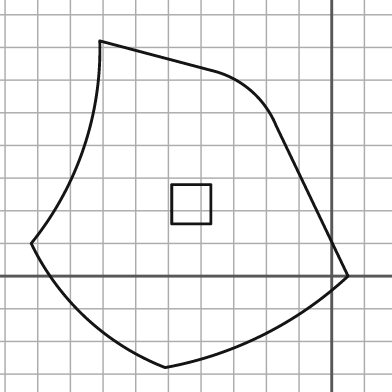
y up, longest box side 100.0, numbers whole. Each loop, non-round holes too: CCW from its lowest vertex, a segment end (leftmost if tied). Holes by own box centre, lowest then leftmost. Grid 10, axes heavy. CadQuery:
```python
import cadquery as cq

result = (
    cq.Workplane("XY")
    .moveTo(-51.0, -28.0)
    .threePointArc((-21.0, -18.0), (5.0, 0.0))
    .lineTo(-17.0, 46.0)
    .threePointArc((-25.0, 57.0), (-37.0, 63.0))
    .lineTo(-71.0, 72.0)
    .threePointArc((-76.0, 39.0), (-92.0, 10.0))
    .threePointArc((-75.0, -13.0), (-51.0, -28.0))
    .close()
    .moveTo(-49.0, 16.0)
    .lineTo(-37.0, 16.0)
    .lineTo(-37.0, 28.0)
    .lineTo(-49.0, 28.0)
    .close()
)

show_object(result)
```